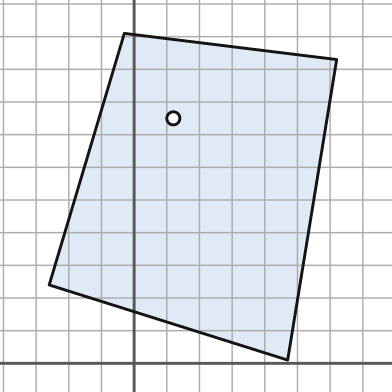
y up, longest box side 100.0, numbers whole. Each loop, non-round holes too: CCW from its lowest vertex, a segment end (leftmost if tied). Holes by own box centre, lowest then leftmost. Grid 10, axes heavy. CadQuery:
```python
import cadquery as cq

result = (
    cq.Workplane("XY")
    .moveTo(47.0, 1.0)
    .lineTo(62.0, 93.0)
    .lineTo(-3.0, 101.0)
    .lineTo(-26.0, 24.0)
    .close()
    .moveTo(12.0, 75.0)
    .circle(2.0)
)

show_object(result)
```